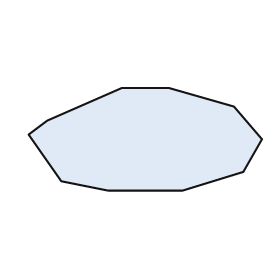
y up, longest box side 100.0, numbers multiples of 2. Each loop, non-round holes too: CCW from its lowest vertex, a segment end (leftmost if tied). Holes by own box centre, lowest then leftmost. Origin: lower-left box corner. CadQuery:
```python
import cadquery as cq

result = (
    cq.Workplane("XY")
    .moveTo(34.0, 0.0)
    .lineTo(66.0, 0.0)
    .lineTo(92.0, 8.0)
    .lineTo(100.0, 22.0)
    .lineTo(88.0, 36.0)
    .lineTo(60.0, 44.0)
    .lineTo(40.0, 44.0)
    .lineTo(8.0, 30.0)
    .lineTo(0.0, 24.0)
    .lineTo(14.0, 4.0)
    .close()
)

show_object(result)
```